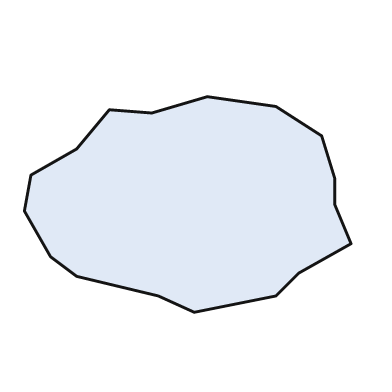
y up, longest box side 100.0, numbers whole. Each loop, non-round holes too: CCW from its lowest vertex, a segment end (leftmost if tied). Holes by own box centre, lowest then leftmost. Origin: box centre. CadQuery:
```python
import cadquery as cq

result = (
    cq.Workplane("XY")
    .moveTo(2.0, -33.0)
    .lineTo(27.0, -28.0)
    .lineTo(34.0, -21.0)
    .lineTo(50.0, -12.0)
    .lineTo(45.0, 0.0)
    .lineTo(45.0, 8.0)
    .lineTo(41.0, 21.0)
    .lineTo(27.0, 30.0)
    .lineTo(6.0, 33.0)
    .lineTo(-11.0, 28.0)
    .lineTo(-24.0, 29.0)
    .lineTo(-34.0, 17.0)
    .lineTo(-48.0, 9.0)
    .lineTo(-50.0, -2.0)
    .lineTo(-42.0, -16.0)
    .lineTo(-34.0, -22.0)
    .lineTo(-9.0, -28.0)
    .close()
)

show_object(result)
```